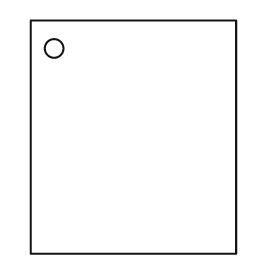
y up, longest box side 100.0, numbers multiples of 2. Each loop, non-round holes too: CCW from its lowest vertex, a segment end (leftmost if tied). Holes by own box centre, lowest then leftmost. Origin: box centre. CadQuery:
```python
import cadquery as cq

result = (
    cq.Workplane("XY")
    .moveTo(-44.0, -50.0)
    .lineTo(44.0, -50.0)
    .lineTo(44.0, 50.0)
    .lineTo(-44.0, 50.0)
    .close()
    .moveTo(-34.0, 38.0)
    .circle(4.0)
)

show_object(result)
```